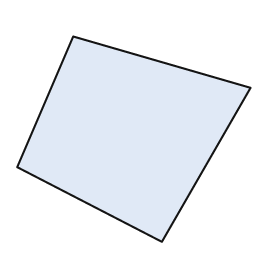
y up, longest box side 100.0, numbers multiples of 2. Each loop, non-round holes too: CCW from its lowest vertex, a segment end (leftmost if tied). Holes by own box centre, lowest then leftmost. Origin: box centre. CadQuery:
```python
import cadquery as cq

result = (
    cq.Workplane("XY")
    .moveTo(12.0, -44.0)
    .lineTo(50.0, 22.0)
    .lineTo(-26.0, 44.0)
    .lineTo(-50.0, -12.0)
    .close()
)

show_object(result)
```